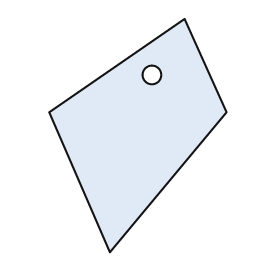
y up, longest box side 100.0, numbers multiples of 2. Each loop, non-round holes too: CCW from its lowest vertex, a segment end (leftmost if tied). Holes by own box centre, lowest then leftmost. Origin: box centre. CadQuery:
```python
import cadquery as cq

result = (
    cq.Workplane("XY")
    .moveTo(-12.0, -50.0)
    .lineTo(38.0, 10.0)
    .lineTo(20.0, 50.0)
    .lineTo(-38.0, 10.0)
    .close()
    .moveTo(6.0, 26.0)
    .circle(4.0)
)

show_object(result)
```